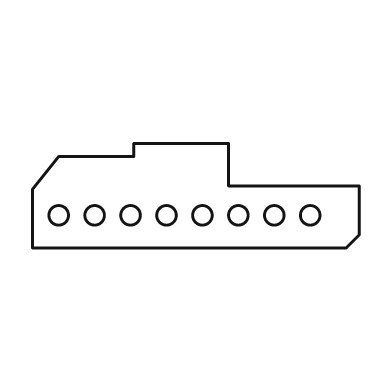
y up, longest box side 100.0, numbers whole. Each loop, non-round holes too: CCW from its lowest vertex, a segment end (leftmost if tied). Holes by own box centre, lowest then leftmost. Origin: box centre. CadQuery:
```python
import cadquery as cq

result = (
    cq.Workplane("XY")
    .moveTo(-50.0, -16.0)
    .lineTo(46.0, -16.0)
    .lineTo(50.0, -12.0)
    .lineTo(50.0, 3.0)
    .lineTo(10.0, 3.0)
    .lineTo(10.0, 16.0)
    .lineTo(-19.0, 16.0)
    .lineTo(-19.0, 12.0)
    .lineTo(-42.0, 12.0)
    .lineTo(-50.0, 2.0)
    .close()
    .moveTo(-42.0, -6.0)
    .circle(3.0)
    .moveTo(-31.0, -6.0)
    .circle(3.0)
    .moveTo(-20.0, -6.0)
    .circle(3.0)
    .moveTo(-9.0, -6.0)
    .circle(3.0)
    .moveTo(2.0, -6.0)
    .circle(3.0)
    .moveTo(13.0, -6.0)
    .circle(3.0)
    .moveTo(24.0, -6.0)
    .circle(3.0)
    .moveTo(35.0, -6.0)
    .circle(3.0)
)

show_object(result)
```